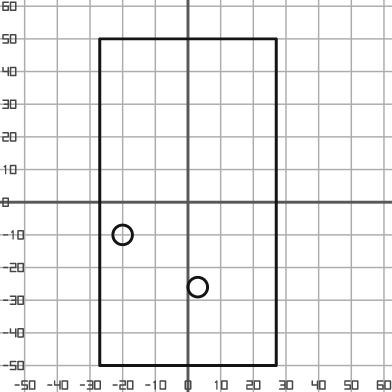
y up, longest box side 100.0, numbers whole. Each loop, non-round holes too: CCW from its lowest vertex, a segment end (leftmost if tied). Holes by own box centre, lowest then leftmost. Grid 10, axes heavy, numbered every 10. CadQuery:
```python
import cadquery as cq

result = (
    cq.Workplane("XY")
    .moveTo(-27.0, -50.0)
    .lineTo(27.0, -50.0)
    .lineTo(27.0, 50.0)
    .lineTo(-27.0, 50.0)
    .close()
    .moveTo(3.0, -26.0)
    .circle(3.0)
    .moveTo(-20.0, -10.0)
    .circle(3.0)
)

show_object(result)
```